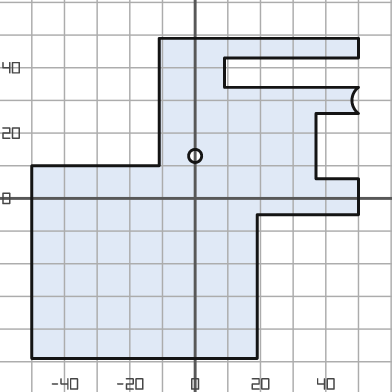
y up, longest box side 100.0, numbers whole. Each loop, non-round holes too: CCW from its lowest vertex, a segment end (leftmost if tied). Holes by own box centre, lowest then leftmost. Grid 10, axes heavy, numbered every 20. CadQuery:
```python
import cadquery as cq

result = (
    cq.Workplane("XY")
    .moveTo(-50.0, -49.0)
    .lineTo(19.0, -49.0)
    .lineTo(19.0, -5.0)
    .lineTo(50.0, -5.0)
    .lineTo(50.0, 6.0)
    .lineTo(37.0, 6.0)
    .lineTo(37.0, 26.0)
    .lineTo(50.0, 26.0)
    .threePointArc((48.0, 30.0), (50.0, 34.0))
    .lineTo(9.0, 34.0)
    .lineTo(9.0, 43.0)
    .lineTo(50.0, 43.0)
    .lineTo(50.0, 49.0)
    .lineTo(-11.0, 49.0)
    .lineTo(-11.0, 10.0)
    .lineTo(-50.0, 10.0)
    .close()
    .moveTo(0.0, 13.0)
    .circle(2.0)
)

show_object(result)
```